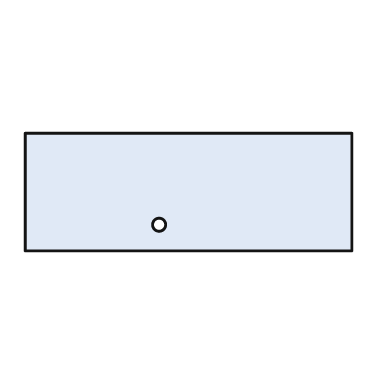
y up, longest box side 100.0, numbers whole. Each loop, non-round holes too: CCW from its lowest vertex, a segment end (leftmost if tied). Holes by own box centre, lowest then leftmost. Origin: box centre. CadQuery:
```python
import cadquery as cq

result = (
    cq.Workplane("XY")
    .moveTo(-50.0, -18.0)
    .lineTo(50.0, -18.0)
    .lineTo(50.0, 18.0)
    .lineTo(-50.0, 18.0)
    .close()
    .moveTo(-9.0, -10.0)
    .circle(2.0)
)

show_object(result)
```